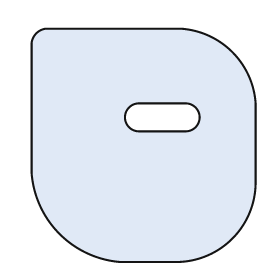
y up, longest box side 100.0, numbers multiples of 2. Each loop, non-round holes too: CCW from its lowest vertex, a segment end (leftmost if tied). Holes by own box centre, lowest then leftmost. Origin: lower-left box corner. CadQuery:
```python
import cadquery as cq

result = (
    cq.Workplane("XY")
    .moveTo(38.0, 0.0)
    .lineTo(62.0, 0.0)
    .threePointArc((86.0, 10.0), (96.0, 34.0))
    .lineTo(96.0, 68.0)
    .threePointArc((86.0, 90.0), (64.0, 100.0))
    .lineTo(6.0, 100.0)
    .threePointArc((2.0, 98.0), (0.0, 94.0))
    .lineTo(0.0, 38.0)
    .threePointArc((12.0, 12.0), (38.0, 0.0))
    .close()
    .moveTo(46.0, 56.0)
    .lineTo(66.0, 56.0)
    .threePointArc((72.0, 62.0), (66.0, 68.0))
    .lineTo(46.0, 68.0)
    .threePointArc((40.0, 62.0), (46.0, 56.0))
    .close()
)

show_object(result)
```